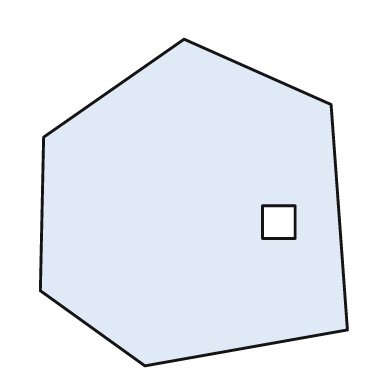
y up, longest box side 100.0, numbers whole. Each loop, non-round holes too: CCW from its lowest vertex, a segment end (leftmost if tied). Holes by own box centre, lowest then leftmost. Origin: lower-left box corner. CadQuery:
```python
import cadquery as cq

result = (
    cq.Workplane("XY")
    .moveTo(32.0, 0.0)
    .lineTo(94.0, 11.0)
    .lineTo(89.0, 80.0)
    .lineTo(44.0, 100.0)
    .lineTo(1.0, 70.0)
    .lineTo(0.0, 23.0)
    .close()
    .moveTo(68.0, 39.0)
    .lineTo(78.0, 39.0)
    .lineTo(78.0, 49.0)
    .lineTo(68.0, 49.0)
    .close()
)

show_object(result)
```